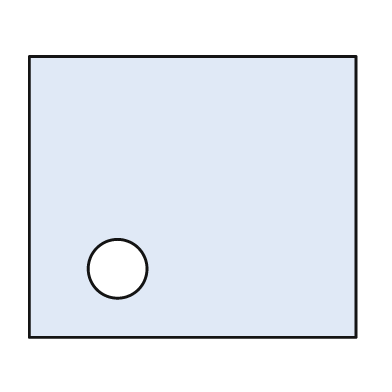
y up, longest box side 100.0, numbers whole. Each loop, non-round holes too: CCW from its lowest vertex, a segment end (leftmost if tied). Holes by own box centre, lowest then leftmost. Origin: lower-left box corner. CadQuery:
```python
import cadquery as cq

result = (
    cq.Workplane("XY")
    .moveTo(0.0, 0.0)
    .lineTo(100.0, 0.0)
    .lineTo(100.0, 86.0)
    .lineTo(0.0, 86.0)
    .close()
    .moveTo(27.0, 21.0)
    .circle(9.0)
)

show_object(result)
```